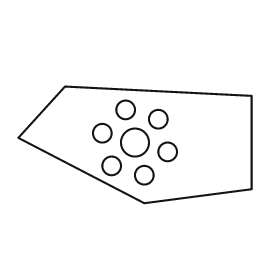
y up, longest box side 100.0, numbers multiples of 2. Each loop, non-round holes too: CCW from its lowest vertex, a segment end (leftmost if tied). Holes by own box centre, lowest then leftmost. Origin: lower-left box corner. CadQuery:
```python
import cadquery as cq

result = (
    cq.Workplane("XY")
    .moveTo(54.0, 0.0)
    .lineTo(100.0, 6.0)
    .lineTo(100.0, 46.0)
    .lineTo(20.0, 50.0)
    .lineTo(0.0, 28.0)
    .close()
    .moveTo(54.0, 12.0)
    .circle(4.0)
    .moveTo(40.0, 16.0)
    .circle(4.0)
    .moveTo(64.0, 22.0)
    .circle(4.0)
    .moveTo(50.0, 26.0)
    .circle(6.0)
    .moveTo(36.0, 30.0)
    .circle(4.0)
    .moveTo(60.0, 36.0)
    .circle(4.0)
    .moveTo(46.0, 40.0)
    .circle(4.0)
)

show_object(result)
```